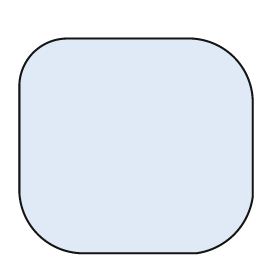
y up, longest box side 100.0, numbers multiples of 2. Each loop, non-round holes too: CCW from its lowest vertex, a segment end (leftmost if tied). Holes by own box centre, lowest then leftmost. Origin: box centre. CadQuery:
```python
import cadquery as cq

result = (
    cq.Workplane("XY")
    .moveTo(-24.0, -46.0)
    .lineTo(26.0, -46.0)
    .threePointArc((42.0, -38.0), (50.0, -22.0))
    .lineTo(50.0, 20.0)
    .threePointArc((42.0, 38.0), (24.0, 46.0))
    .lineTo(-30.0, 46.0)
    .threePointArc((-44.0, 40.0), (-50.0, 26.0))
    .lineTo(-50.0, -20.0)
    .threePointArc((-42.0, -38.0), (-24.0, -46.0))
    .close()
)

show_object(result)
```